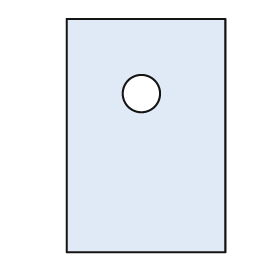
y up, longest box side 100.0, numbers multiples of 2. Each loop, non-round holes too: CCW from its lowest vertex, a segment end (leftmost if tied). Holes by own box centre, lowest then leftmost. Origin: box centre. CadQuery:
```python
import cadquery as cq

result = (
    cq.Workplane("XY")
    .moveTo(-34.0, -50.0)
    .lineTo(34.0, -50.0)
    .lineTo(34.0, 50.0)
    .lineTo(-34.0, 50.0)
    .close()
    .moveTo(-2.0, 18.0)
    .circle(8.0)
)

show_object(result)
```